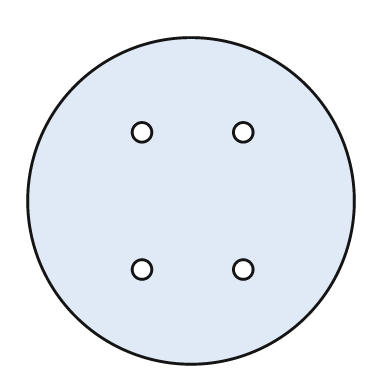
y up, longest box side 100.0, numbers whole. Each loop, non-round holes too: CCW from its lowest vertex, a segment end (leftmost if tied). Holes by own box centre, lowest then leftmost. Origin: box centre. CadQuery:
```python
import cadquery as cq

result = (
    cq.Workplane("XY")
    .moveTo(0.0, 0.0)
    .circle(50.0)
    .moveTo(-15.0, -21.0)
    .circle(3.0)
    .moveTo(16.0, -21.0)
    .circle(3.0)
    .moveTo(-15.0, 21.0)
    .circle(3.0)
    .moveTo(16.0, 21.0)
    .circle(3.0)
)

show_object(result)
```